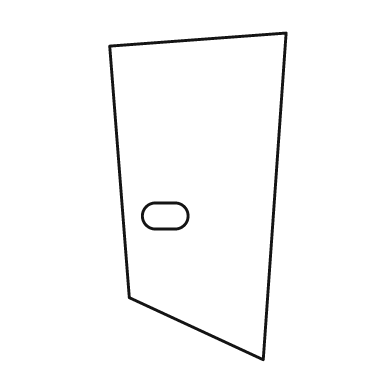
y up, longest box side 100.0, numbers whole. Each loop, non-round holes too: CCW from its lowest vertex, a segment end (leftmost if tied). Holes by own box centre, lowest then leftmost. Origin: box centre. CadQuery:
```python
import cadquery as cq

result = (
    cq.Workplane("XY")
    .moveTo(20.0, -50.0)
    .lineTo(27.0, 50.0)
    .lineTo(-27.0, 46.0)
    .lineTo(-21.0, -31.0)
    .close()
    .moveTo(-13.0, -10.0)
    .lineTo(-7.0, -10.0)
    .threePointArc((-3.0, -6.0), (-7.0, -2.0))
    .lineTo(-13.0, -2.0)
    .threePointArc((-17.0, -6.0), (-13.0, -10.0))
    .close()
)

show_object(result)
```